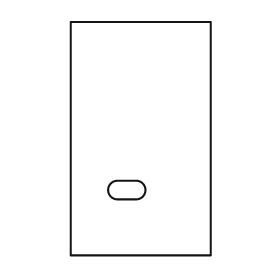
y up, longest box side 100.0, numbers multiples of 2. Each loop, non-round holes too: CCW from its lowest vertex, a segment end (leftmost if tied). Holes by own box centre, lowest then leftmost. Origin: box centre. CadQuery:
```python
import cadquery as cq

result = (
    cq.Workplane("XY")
    .moveTo(-30.0, -50.0)
    .lineTo(30.0, -50.0)
    .lineTo(30.0, 50.0)
    .lineTo(-30.0, 50.0)
    .close()
    .moveTo(-10.0, -26.0)
    .lineTo(-2.0, -26.0)
    .threePointArc((2.0, -22.0), (-2.0, -18.0))
    .lineTo(-10.0, -18.0)
    .threePointArc((-14.0, -22.0), (-10.0, -26.0))
    .close()
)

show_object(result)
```